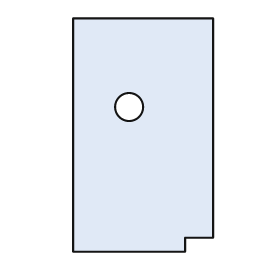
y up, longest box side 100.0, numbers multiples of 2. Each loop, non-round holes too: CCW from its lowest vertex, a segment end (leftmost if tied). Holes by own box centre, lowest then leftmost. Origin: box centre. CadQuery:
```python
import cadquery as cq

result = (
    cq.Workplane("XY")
    .moveTo(-30.0, -50.0)
    .lineTo(18.0, -50.0)
    .lineTo(18.0, -44.0)
    .lineTo(30.0, -44.0)
    .lineTo(30.0, 50.0)
    .lineTo(-30.0, 50.0)
    .close()
    .moveTo(-6.0, 12.0)
    .circle(6.0)
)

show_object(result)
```